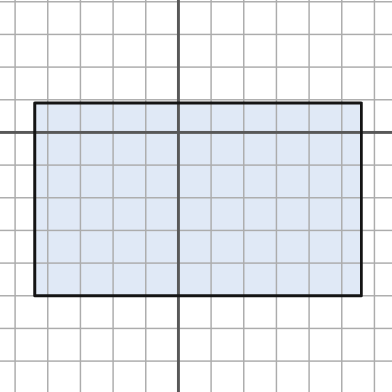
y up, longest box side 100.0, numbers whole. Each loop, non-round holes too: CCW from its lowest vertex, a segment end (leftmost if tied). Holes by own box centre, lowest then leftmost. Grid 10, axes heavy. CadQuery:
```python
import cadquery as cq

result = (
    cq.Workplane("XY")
    .moveTo(-44.0, -50.0)
    .lineTo(56.0, -50.0)
    .lineTo(56.0, 9.0)
    .lineTo(-44.0, 9.0)
    .close()
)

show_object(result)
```